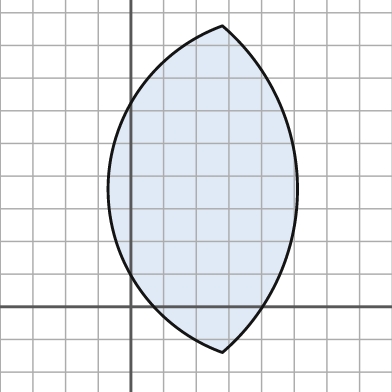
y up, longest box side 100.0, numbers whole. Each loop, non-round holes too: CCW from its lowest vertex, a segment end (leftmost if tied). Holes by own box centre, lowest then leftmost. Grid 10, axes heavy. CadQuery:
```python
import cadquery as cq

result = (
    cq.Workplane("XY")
    .moveTo(28.0, -14.0)
    .threePointArc((51.0, 36.0), (28.0, 86.0))
    .threePointArc((-7.0, 36.0), (28.0, -14.0))
    .close()
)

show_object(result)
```